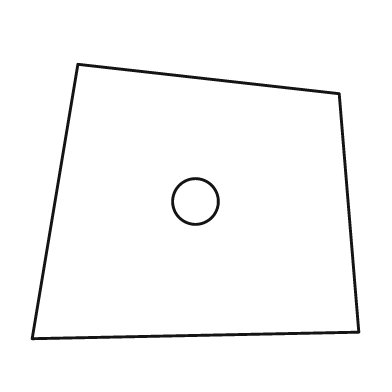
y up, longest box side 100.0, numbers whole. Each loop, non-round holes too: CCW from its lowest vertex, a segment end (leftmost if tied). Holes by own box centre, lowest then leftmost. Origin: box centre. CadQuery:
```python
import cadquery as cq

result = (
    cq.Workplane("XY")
    .moveTo(-50.0, -42.0)
    .lineTo(50.0, -40.0)
    .lineTo(44.0, 33.0)
    .lineTo(-36.0, 42.0)
    .close()
    .moveTo(0.0, 0.0)
    .circle(7.0)
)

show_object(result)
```